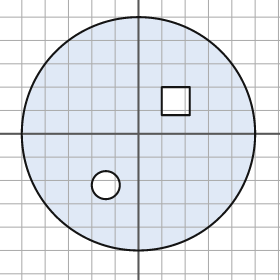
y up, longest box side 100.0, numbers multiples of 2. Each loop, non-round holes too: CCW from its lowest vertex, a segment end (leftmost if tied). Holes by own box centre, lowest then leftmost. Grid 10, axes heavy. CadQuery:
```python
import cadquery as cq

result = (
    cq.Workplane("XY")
    .moveTo(0.0, 0.0)
    .circle(50.0)
    .moveTo(-14.0, -22.0)
    .circle(6.0)
    .moveTo(10.0, 8.0)
    .lineTo(22.0, 8.0)
    .lineTo(22.0, 20.0)
    .lineTo(10.0, 20.0)
    .close()
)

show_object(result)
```